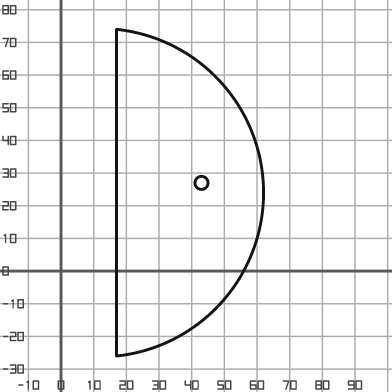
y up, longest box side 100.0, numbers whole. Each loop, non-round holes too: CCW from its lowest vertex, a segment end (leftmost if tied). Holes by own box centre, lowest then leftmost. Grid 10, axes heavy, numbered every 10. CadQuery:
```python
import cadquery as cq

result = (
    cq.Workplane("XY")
    .moveTo(17.0, -26.0)
    .threePointArc((62.0, 24.0), (17.0, 74.0))
    .close()
    .moveTo(43.0, 27.0)
    .circle(2.0)
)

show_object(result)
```